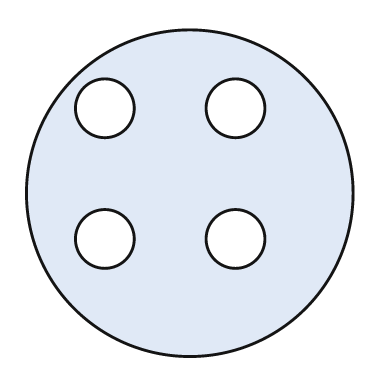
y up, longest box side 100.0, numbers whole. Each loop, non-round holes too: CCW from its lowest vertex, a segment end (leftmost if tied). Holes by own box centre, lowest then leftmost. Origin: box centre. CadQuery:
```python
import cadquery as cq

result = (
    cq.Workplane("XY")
    .moveTo(0.0, 0.0)
    .circle(50.0)
    .moveTo(-26.0, -14.0)
    .circle(9.0)
    .moveTo(14.0, -14.0)
    .circle(9.0)
    .moveTo(-26.0, 26.0)
    .circle(9.0)
    .moveTo(14.0, 26.0)
    .circle(9.0)
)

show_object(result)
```